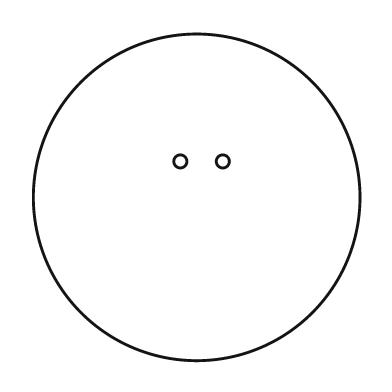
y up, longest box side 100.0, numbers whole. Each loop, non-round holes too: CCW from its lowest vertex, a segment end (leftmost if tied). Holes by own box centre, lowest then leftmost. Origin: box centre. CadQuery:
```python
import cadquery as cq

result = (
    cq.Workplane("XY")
    .moveTo(0.0, 0.0)
    .circle(50.0)
    .moveTo(-5.0, 11.0)
    .circle(2.0)
    .moveTo(8.0, 11.0)
    .circle(2.0)
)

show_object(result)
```